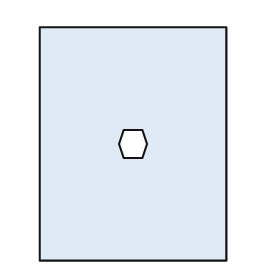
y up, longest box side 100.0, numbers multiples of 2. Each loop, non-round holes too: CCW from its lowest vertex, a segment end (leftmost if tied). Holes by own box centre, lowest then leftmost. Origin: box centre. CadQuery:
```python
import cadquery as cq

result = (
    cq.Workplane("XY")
    .moveTo(-40.0, -50.0)
    .lineTo(40.0, -50.0)
    .lineTo(40.0, 50.0)
    .lineTo(-40.0, 50.0)
    .close()
    .moveTo(-4.0, -6.0)
    .lineTo(4.0, -6.0)
    .lineTo(6.0, 0.0)
    .lineTo(4.0, 6.0)
    .lineTo(-4.0, 6.0)
    .lineTo(-6.0, 0.0)
    .close()
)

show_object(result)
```